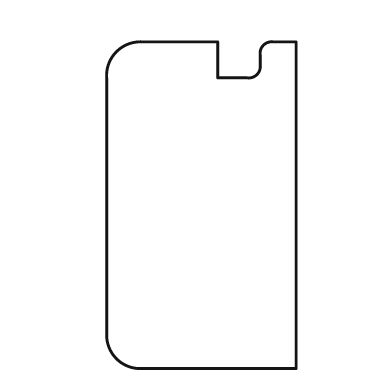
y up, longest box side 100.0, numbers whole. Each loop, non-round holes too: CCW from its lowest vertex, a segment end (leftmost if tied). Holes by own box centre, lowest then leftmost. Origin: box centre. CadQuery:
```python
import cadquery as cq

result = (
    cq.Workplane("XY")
    .moveTo(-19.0, -50.0)
    .lineTo(29.0, -50.0)
    .lineTo(29.0, 50.0)
    .lineTo(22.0, 50.0)
    .threePointArc((19.0, 49.0), (18.0, 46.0))
    .lineTo(18.0, 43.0)
    .threePointArc((17.0, 40.0), (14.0, 39.0))
    .lineTo(5.0, 39.0)
    .lineTo(5.0, 50.0)
    .lineTo(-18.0, 50.0)
    .threePointArc((-26.0, 47.0), (-29.0, 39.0))
    .lineTo(-29.0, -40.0)
    .threePointArc((-26.0, -47.0), (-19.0, -50.0))
    .close()
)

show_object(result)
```